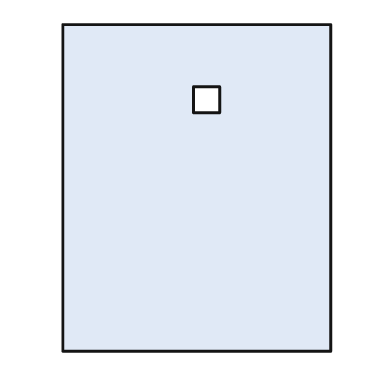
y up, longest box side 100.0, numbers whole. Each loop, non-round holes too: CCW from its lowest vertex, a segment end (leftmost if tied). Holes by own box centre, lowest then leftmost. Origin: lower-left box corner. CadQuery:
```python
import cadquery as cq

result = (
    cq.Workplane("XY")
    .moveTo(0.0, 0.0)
    .lineTo(82.0, 0.0)
    .lineTo(82.0, 100.0)
    .lineTo(0.0, 100.0)
    .close()
    .moveTo(40.0, 73.0)
    .lineTo(48.0, 73.0)
    .lineTo(48.0, 81.0)
    .lineTo(40.0, 81.0)
    .close()
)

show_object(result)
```